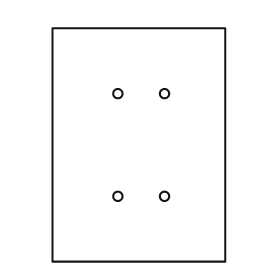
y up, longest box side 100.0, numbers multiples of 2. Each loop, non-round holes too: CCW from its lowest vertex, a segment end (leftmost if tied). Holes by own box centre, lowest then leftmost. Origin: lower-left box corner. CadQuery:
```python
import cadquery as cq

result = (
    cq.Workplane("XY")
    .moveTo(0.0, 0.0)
    .lineTo(74.0, 0.0)
    .lineTo(74.0, 100.0)
    .lineTo(0.0, 100.0)
    .close()
    .moveTo(28.0, 28.0)
    .circle(2.0)
    .moveTo(48.0, 28.0)
    .circle(2.0)
    .moveTo(28.0, 72.0)
    .circle(2.0)
    .moveTo(48.0, 72.0)
    .circle(2.0)
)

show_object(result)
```